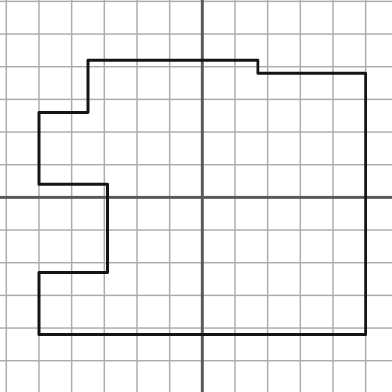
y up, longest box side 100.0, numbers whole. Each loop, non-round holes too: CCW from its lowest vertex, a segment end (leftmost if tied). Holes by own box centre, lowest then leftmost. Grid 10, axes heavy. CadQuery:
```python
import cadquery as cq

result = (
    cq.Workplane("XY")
    .moveTo(-50.0, -42.0)
    .lineTo(50.0, -42.0)
    .lineTo(50.0, 38.0)
    .lineTo(17.0, 38.0)
    .lineTo(17.0, 42.0)
    .lineTo(-35.0, 42.0)
    .lineTo(-35.0, 26.0)
    .lineTo(-50.0, 26.0)
    .lineTo(-50.0, 4.0)
    .lineTo(-29.0, 4.0)
    .lineTo(-29.0, -23.0)
    .lineTo(-50.0, -23.0)
    .close()
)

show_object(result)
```